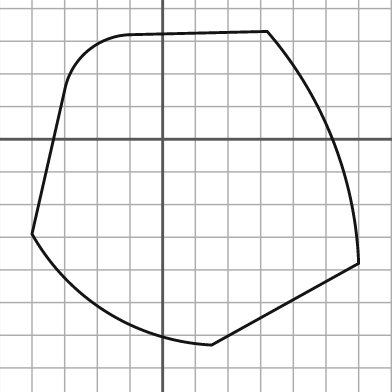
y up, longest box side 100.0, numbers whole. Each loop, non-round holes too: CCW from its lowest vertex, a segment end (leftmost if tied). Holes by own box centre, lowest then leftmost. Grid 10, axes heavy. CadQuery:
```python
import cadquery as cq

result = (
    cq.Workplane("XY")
    .moveTo(15.0, -63.0)
    .lineTo(60.0, -38.0)
    .threePointArc((52.0, 0.0), (32.0, 33.0))
    .lineTo(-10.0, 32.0)
    .threePointArc((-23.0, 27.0), (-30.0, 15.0))
    .lineTo(-40.0, -29.0)
    .threePointArc((-17.0, -53.0), (15.0, -63.0))
    .close()
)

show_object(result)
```